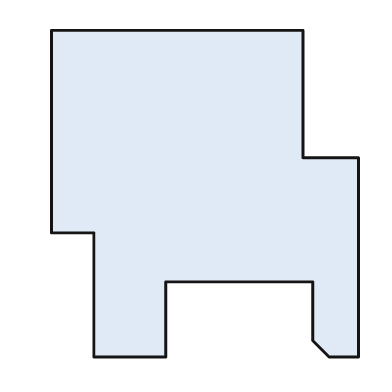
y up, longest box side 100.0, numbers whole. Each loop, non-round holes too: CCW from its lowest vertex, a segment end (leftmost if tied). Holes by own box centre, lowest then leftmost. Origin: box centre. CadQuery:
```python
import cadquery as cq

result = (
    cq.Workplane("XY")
    .moveTo(-34.0, -50.0)
    .lineTo(-12.0, -50.0)
    .lineTo(-12.0, -27.0)
    .lineTo(33.0, -27.0)
    .lineTo(33.0, -45.0)
    .lineTo(38.0, -50.0)
    .lineTo(47.0, -50.0)
    .lineTo(47.0, 11.0)
    .lineTo(30.0, 11.0)
    .lineTo(30.0, 50.0)
    .lineTo(-47.0, 50.0)
    .lineTo(-47.0, -12.0)
    .lineTo(-34.0, -12.0)
    .close()
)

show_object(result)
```